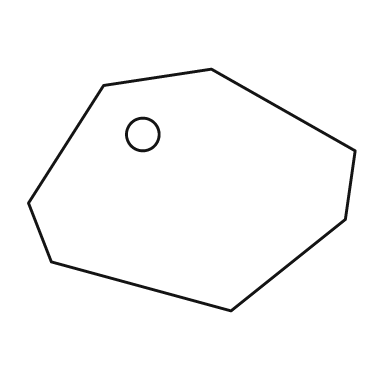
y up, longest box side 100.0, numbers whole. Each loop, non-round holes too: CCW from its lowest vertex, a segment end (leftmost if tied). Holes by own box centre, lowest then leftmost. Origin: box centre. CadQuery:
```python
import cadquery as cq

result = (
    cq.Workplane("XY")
    .moveTo(12.0, -37.0)
    .lineTo(47.0, -9.0)
    .lineTo(50.0, 12.0)
    .lineTo(6.0, 37.0)
    .lineTo(-27.0, 32.0)
    .lineTo(-50.0, -4.0)
    .lineTo(-43.0, -22.0)
    .close()
    .moveTo(-15.0, 17.0)
    .circle(5.0)
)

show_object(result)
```